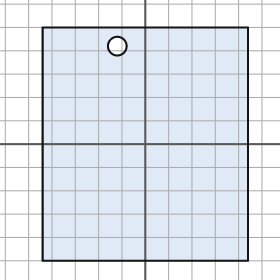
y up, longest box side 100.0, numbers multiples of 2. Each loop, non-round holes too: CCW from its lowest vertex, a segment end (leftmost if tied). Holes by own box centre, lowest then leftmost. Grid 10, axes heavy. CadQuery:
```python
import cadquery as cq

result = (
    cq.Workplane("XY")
    .moveTo(-44.0, -50.0)
    .lineTo(44.0, -50.0)
    .lineTo(44.0, 50.0)
    .lineTo(-44.0, 50.0)
    .close()
    .moveTo(-12.0, 42.0)
    .circle(4.0)
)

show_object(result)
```